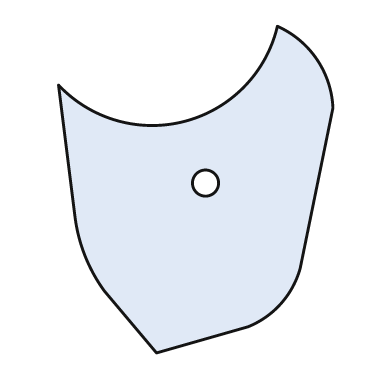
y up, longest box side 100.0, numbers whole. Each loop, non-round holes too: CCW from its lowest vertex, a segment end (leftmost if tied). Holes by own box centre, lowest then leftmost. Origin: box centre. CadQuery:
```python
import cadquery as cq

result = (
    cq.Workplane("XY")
    .moveTo(-12.0, -50.0)
    .lineTo(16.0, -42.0)
    .threePointArc((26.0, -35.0), (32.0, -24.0))
    .lineTo(42.0, 25.0)
    .threePointArc((37.0, 40.0), (25.0, 50.0))
    .threePointArc((-3.0, 21.0), (-42.0, 32.0))
    .lineTo(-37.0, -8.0)
    .threePointArc((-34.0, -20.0), (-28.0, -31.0))
    .close()
    .moveTo(3.0, 2.0)
    .circle(4.0)
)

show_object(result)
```